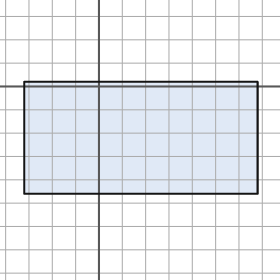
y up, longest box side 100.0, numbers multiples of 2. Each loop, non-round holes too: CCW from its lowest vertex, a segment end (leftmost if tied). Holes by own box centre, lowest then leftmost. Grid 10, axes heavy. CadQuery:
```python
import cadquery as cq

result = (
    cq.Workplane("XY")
    .moveTo(-32.0, -46.0)
    .lineTo(68.0, -46.0)
    .lineTo(68.0, 2.0)
    .lineTo(-32.0, 2.0)
    .close()
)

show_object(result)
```